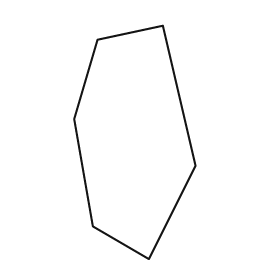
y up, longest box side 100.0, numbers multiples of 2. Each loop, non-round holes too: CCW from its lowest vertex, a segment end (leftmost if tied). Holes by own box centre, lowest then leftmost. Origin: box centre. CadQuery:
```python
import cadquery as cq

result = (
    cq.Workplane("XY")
    .moveTo(6.0, -50.0)
    .lineTo(26.0, -10.0)
    .lineTo(12.0, 50.0)
    .lineTo(-16.0, 44.0)
    .lineTo(-26.0, 10.0)
    .lineTo(-18.0, -36.0)
    .close()
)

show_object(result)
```